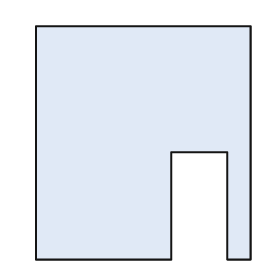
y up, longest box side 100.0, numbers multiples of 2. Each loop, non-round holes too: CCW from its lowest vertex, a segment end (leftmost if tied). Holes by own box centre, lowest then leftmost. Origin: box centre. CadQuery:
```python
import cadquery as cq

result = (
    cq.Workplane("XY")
    .moveTo(-46.0, -50.0)
    .lineTo(12.0, -50.0)
    .lineTo(12.0, -4.0)
    .lineTo(36.0, -4.0)
    .lineTo(36.0, -50.0)
    .lineTo(46.0, -50.0)
    .lineTo(46.0, 50.0)
    .lineTo(-46.0, 50.0)
    .close()
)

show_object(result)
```